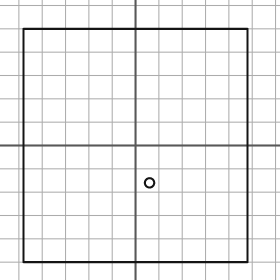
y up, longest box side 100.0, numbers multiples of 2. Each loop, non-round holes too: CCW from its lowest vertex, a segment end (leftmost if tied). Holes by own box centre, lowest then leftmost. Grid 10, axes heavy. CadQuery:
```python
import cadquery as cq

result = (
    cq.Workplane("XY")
    .moveTo(-48.0, -50.0)
    .lineTo(48.0, -50.0)
    .lineTo(48.0, 50.0)
    .lineTo(-48.0, 50.0)
    .close()
    .moveTo(6.0, -16.0)
    .circle(2.0)
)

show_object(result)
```